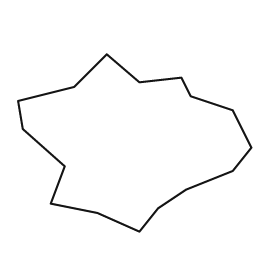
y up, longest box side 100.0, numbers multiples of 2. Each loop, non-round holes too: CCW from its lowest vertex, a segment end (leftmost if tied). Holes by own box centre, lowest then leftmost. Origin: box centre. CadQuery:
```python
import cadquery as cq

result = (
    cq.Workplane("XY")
    .moveTo(2.0, -38.0)
    .lineTo(10.0, -28.0)
    .lineTo(22.0, -20.0)
    .lineTo(42.0, -12.0)
    .lineTo(50.0, -2.0)
    .lineTo(42.0, 14.0)
    .lineTo(24.0, 20.0)
    .lineTo(20.0, 28.0)
    .lineTo(2.0, 26.0)
    .lineTo(-12.0, 38.0)
    .lineTo(-26.0, 24.0)
    .lineTo(-50.0, 18.0)
    .lineTo(-48.0, 6.0)
    .lineTo(-30.0, -10.0)
    .lineTo(-36.0, -26.0)
    .lineTo(-16.0, -30.0)
    .close()
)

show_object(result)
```